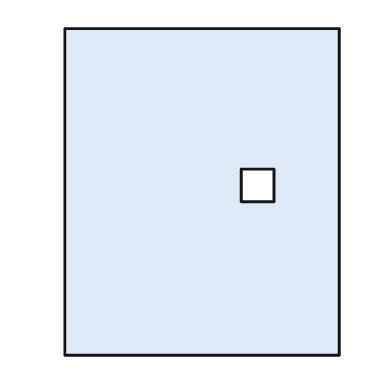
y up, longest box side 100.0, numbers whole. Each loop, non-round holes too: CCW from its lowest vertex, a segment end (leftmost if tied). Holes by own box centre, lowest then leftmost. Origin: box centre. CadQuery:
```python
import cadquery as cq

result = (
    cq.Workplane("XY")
    .moveTo(-42.0, -50.0)
    .lineTo(42.0, -50.0)
    .lineTo(42.0, 50.0)
    .lineTo(-42.0, 50.0)
    .close()
    .moveTo(12.0, -3.0)
    .lineTo(22.0, -3.0)
    .lineTo(22.0, 7.0)
    .lineTo(12.0, 7.0)
    .close()
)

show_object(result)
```